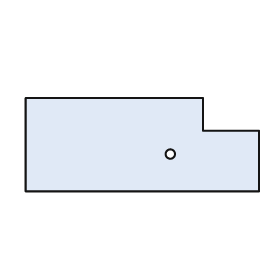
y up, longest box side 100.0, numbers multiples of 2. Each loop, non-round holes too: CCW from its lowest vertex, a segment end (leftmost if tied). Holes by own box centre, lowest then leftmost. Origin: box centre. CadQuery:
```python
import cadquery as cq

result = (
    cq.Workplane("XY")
    .moveTo(-50.0, -20.0)
    .lineTo(50.0, -20.0)
    .lineTo(50.0, 6.0)
    .lineTo(26.0, 6.0)
    .lineTo(26.0, 20.0)
    .lineTo(-50.0, 20.0)
    .close()
    .moveTo(12.0, -4.0)
    .circle(2.0)
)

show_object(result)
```